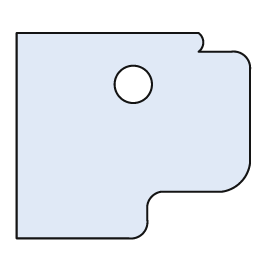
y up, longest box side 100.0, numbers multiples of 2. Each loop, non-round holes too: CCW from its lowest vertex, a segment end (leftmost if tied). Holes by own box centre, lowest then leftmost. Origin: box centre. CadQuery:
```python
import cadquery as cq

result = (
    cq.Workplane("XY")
    .moveTo(-50.0, -44.0)
    .lineTo(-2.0, -44.0)
    .threePointArc((4.0, -42.0), (6.0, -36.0))
    .lineTo(6.0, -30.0)
    .threePointArc((8.0, -26.0), (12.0, -24.0))
    .lineTo(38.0, -24.0)
    .threePointArc((46.0, -20.0), (50.0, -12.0))
    .lineTo(50.0, 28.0)
    .threePointArc((48.0, 34.0), (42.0, 36.0))
    .lineTo(28.0, 36.0)
    .threePointArc((30.0, 40.0), (28.0, 44.0))
    .lineTo(-50.0, 44.0)
    .close()
    .moveTo(0.0, 22.0)
    .circle(8.0)
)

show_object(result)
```